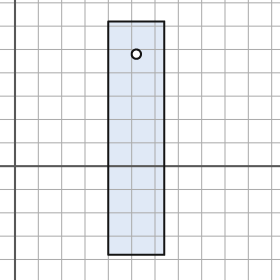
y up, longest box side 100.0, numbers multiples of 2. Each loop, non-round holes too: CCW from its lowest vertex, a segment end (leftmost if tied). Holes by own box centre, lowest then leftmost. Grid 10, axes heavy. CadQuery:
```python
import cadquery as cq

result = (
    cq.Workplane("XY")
    .moveTo(40.0, -38.0)
    .lineTo(64.0, -38.0)
    .lineTo(64.0, 62.0)
    .lineTo(40.0, 62.0)
    .close()
    .moveTo(52.0, 48.0)
    .circle(2.0)
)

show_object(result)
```